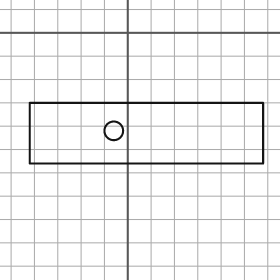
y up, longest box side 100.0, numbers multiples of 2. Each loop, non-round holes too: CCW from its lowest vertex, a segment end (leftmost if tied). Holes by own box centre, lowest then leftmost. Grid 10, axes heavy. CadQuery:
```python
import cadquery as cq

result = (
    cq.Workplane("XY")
    .moveTo(-42.0, -56.0)
    .lineTo(58.0, -56.0)
    .lineTo(58.0, -30.0)
    .lineTo(-42.0, -30.0)
    .close()
    .moveTo(-6.0, -42.0)
    .circle(4.0)
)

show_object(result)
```